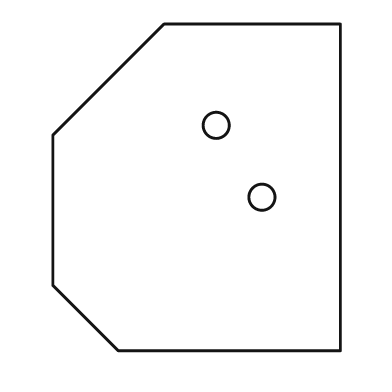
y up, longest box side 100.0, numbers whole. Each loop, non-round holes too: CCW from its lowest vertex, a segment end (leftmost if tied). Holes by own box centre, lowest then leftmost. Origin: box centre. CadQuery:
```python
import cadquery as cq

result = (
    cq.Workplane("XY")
    .moveTo(-24.0, -50.0)
    .lineTo(44.0, -50.0)
    .lineTo(44.0, 50.0)
    .lineTo(-10.0, 50.0)
    .lineTo(-44.0, 16.0)
    .lineTo(-44.0, -30.0)
    .close()
    .moveTo(20.0, -3.0)
    .circle(4.0)
    .moveTo(6.0, 19.0)
    .circle(4.0)
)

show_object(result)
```